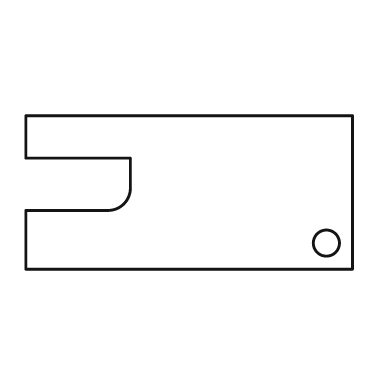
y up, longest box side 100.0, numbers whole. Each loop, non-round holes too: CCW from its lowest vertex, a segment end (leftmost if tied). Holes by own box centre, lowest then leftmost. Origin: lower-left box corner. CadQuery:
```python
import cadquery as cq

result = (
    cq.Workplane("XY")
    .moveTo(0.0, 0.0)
    .lineTo(100.0, 0.0)
    .lineTo(100.0, 47.0)
    .lineTo(0.0, 47.0)
    .lineTo(0.0, 34.0)
    .lineTo(32.0, 34.0)
    .lineTo(32.0, 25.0)
    .threePointArc((30.0, 20.0), (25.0, 18.0))
    .lineTo(0.0, 18.0)
    .close()
    .moveTo(92.0, 8.0)
    .circle(4.0)
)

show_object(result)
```